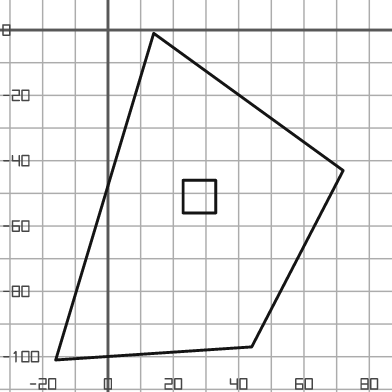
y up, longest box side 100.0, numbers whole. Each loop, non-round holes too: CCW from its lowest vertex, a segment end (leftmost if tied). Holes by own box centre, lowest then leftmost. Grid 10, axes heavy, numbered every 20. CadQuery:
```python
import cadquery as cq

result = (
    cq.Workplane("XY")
    .moveTo(-16.0, -101.0)
    .lineTo(44.0, -97.0)
    .lineTo(72.0, -43.0)
    .lineTo(14.0, -1.0)
    .close()
    .moveTo(23.0, -56.0)
    .lineTo(33.0, -56.0)
    .lineTo(33.0, -46.0)
    .lineTo(23.0, -46.0)
    .close()
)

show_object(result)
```